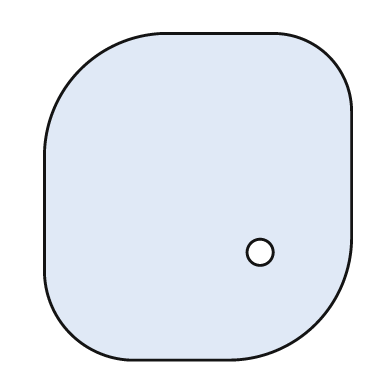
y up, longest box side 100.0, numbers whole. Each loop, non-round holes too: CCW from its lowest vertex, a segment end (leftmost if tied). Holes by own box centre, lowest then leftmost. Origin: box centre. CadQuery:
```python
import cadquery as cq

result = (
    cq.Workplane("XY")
    .moveTo(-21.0, -50.0)
    .lineTo(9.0, -50.0)
    .threePointArc((36.0, -39.0), (47.0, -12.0))
    .lineTo(47.0, 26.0)
    .threePointArc((40.0, 43.0), (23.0, 50.0))
    .lineTo(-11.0, 50.0)
    .threePointArc((-36.0, 39.0), (-47.0, 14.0))
    .lineTo(-47.0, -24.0)
    .threePointArc((-39.0, -42.0), (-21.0, -50.0))
    .close()
    .moveTo(19.0, -17.0)
    .circle(4.0)
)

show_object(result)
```